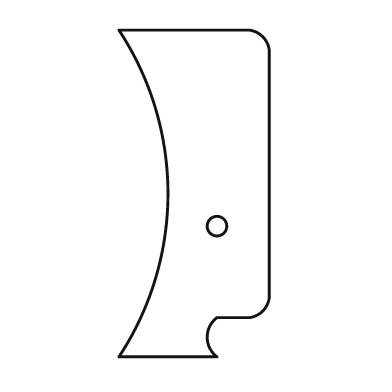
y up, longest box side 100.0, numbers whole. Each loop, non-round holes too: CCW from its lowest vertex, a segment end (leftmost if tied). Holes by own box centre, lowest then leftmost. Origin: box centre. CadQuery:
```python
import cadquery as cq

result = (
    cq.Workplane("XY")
    .moveTo(-23.0, -50.0)
    .lineTo(7.0, -50.0)
    .threePointArc((4.0, -44.0), (7.0, -38.0))
    .lineTo(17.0, -38.0)
    .threePointArc((21.0, -36.0), (23.0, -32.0))
    .lineTo(23.0, 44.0)
    .threePointArc((21.0, 48.0), (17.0, 50.0))
    .lineTo(-23.0, 50.0)
    .threePointArc((-8.0, 0.0), (-23.0, -50.0))
    .close()
    .moveTo(7.0, -10.0)
    .circle(3.0)
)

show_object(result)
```